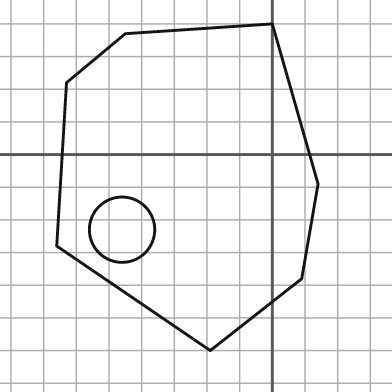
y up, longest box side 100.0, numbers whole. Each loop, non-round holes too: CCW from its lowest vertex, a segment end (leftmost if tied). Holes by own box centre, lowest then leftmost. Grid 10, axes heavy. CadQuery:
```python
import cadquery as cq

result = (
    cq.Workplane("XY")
    .moveTo(-19.0, -60.0)
    .lineTo(9.0, -38.0)
    .lineTo(14.0, -9.0)
    .lineTo(0.0, 40.0)
    .lineTo(-45.0, 37.0)
    .lineTo(-63.0, 22.0)
    .lineTo(-66.0, -28.0)
    .close()
    .moveTo(-46.0, -23.0)
    .circle(10.0)
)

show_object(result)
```